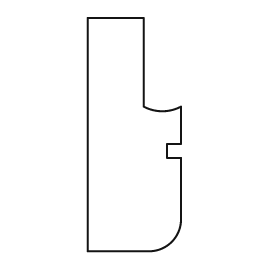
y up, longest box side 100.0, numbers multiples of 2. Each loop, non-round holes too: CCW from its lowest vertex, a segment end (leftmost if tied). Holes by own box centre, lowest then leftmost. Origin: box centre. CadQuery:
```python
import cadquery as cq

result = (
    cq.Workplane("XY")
    .moveTo(-20.0, -50.0)
    .lineTo(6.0, -50.0)
    .threePointArc((16.0, -46.0), (20.0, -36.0))
    .lineTo(20.0, -10.0)
    .lineTo(14.0, -10.0)
    .lineTo(14.0, -4.0)
    .lineTo(20.0, -4.0)
    .lineTo(20.0, 12.0)
    .threePointArc((12.0, 10.0), (4.0, 12.0))
    .lineTo(4.0, 50.0)
    .lineTo(-20.0, 50.0)
    .close()
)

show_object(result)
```